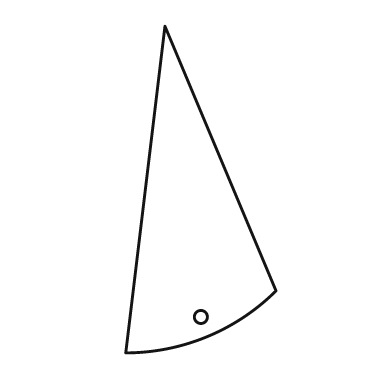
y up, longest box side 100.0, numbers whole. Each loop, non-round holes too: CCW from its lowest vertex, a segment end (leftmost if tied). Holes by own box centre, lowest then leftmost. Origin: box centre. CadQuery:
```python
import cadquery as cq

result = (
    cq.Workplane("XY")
    .moveTo(-23.0, -50.0)
    .threePointArc((2.0, -45.0), (23.0, -31.0))
    .lineTo(-11.0, 50.0)
    .close()
    .moveTo(0.0, -39.0)
    .circle(2.0)
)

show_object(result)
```